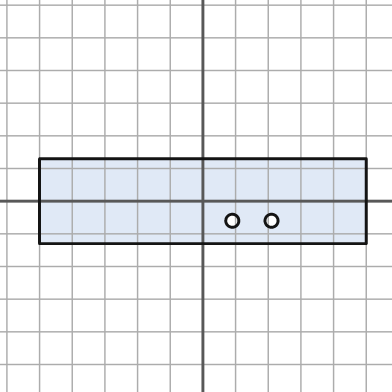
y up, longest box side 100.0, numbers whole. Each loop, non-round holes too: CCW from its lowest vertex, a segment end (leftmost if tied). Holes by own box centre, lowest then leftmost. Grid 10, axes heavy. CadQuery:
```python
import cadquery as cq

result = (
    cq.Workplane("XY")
    .moveTo(-50.0, -13.0)
    .lineTo(50.0, -13.0)
    .lineTo(50.0, 13.0)
    .lineTo(-50.0, 13.0)
    .close()
    .moveTo(9.0, -6.0)
    .circle(2.0)
    .moveTo(21.0, -6.0)
    .circle(2.0)
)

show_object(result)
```